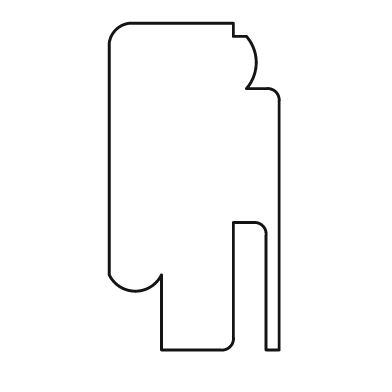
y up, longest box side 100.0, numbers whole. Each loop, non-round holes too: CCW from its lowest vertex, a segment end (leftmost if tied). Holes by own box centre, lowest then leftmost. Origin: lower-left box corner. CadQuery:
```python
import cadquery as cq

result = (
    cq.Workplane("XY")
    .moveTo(16.0, 0.0)
    .lineTo(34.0, 0.0)
    .threePointArc((37.0, 1.0), (38.0, 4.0))
    .lineTo(38.0, 39.0)
    .lineTo(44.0, 39.0)
    .threePointArc((47.0, 38.0), (48.0, 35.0))
    .lineTo(48.0, 0.0)
    .lineTo(52.0, 0.0)
    .lineTo(52.0, 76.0)
    .threePointArc((51.0, 79.0), (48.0, 80.0))
    .lineTo(42.0, 80.0)
    .threePointArc((45.0, 88.0), (42.0, 96.0))
    .lineTo(38.0, 96.0)
    .lineTo(38.0, 100.0)
    .lineTo(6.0, 100.0)
    .threePointArc((2.0, 98.0), (0.0, 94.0))
    .lineTo(0.0, 23.0)
    .threePointArc((8.0, 18.0), (16.0, 23.0))
    .close()
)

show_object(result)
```